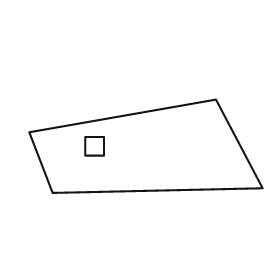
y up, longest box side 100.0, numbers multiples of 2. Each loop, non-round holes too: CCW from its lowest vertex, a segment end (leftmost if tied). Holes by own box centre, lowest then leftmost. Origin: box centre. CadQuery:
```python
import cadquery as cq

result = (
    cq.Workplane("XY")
    .moveTo(-40.0, -20.0)
    .lineTo(50.0, -18.0)
    .lineTo(30.0, 20.0)
    .lineTo(-50.0, 6.0)
    .close()
    .moveTo(-26.0, -4.0)
    .lineTo(-18.0, -4.0)
    .lineTo(-18.0, 4.0)
    .lineTo(-26.0, 4.0)
    .close()
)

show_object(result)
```